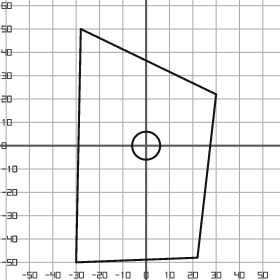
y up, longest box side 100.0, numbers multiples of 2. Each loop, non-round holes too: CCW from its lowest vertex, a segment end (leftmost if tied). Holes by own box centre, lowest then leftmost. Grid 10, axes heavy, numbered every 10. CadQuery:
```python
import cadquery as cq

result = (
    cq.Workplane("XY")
    .moveTo(-30.0, -50.0)
    .lineTo(22.0, -48.0)
    .lineTo(30.0, 22.0)
    .lineTo(-28.0, 50.0)
    .close()
    .moveTo(0.0, 0.0)
    .circle(6.0)
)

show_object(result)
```